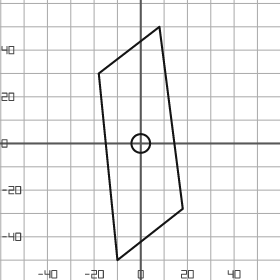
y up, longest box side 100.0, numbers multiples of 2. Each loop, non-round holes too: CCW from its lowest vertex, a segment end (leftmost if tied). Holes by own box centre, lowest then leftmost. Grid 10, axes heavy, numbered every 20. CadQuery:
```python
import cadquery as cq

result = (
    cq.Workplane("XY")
    .moveTo(-10.0, -50.0)
    .lineTo(18.0, -28.0)
    .lineTo(8.0, 50.0)
    .lineTo(-18.0, 30.0)
    .close()
    .moveTo(0.0, 0.0)
    .circle(4.0)
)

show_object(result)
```